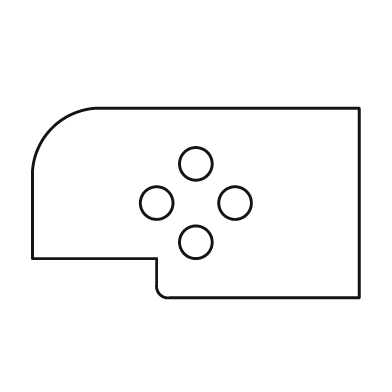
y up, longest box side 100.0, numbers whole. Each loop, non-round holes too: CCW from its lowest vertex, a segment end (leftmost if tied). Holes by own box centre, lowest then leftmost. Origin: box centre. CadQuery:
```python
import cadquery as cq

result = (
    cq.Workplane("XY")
    .moveTo(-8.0, -29.0)
    .lineTo(50.0, -29.0)
    .lineTo(50.0, 29.0)
    .lineTo(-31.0, 29.0)
    .threePointArc((-44.0, 23.0), (-50.0, 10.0))
    .lineTo(-50.0, -17.0)
    .lineTo(-12.0, -17.0)
    .lineTo(-12.0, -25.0)
    .threePointArc((-11.0, -28.0), (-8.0, -29.0))
    .close()
    .moveTo(0.0, -12.0)
    .circle(5.0)
    .moveTo(-12.0, 0.0)
    .circle(5.0)
    .moveTo(12.0, 0.0)
    .circle(5.0)
    .moveTo(0.0, 12.0)
    .circle(5.0)
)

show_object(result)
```